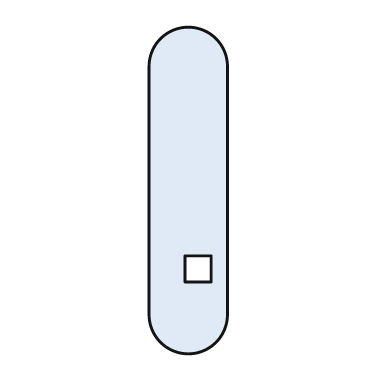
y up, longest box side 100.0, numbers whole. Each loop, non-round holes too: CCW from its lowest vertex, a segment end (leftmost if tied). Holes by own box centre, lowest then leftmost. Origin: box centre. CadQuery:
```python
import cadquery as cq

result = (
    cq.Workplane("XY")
    .moveTo(-12.0, -38.0)
    .threePointArc((0.0, -50.0), (12.0, -38.0))
    .lineTo(12.0, 38.0)
    .threePointArc((0.0, 50.0), (-12.0, 38.0))
    .close()
    .moveTo(-1.0, -28.0)
    .lineTo(7.0, -28.0)
    .lineTo(7.0, -20.0)
    .lineTo(-1.0, -20.0)
    .close()
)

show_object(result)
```